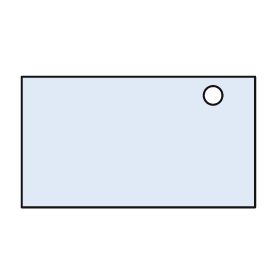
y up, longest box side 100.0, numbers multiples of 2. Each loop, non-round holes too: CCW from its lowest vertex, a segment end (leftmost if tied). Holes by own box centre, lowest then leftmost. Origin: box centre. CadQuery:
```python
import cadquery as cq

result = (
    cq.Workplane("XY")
    .moveTo(-50.0, -28.0)
    .lineTo(50.0, -28.0)
    .lineTo(50.0, 28.0)
    .lineTo(-50.0, 28.0)
    .close()
    .moveTo(32.0, 20.0)
    .circle(4.0)
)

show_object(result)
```